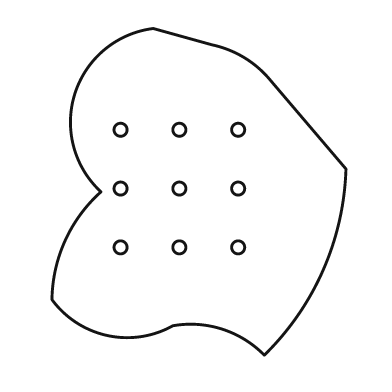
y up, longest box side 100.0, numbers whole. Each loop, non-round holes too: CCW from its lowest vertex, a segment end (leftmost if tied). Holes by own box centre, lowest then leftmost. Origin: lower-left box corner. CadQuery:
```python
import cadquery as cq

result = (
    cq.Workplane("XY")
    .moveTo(65.0, 0.0)
    .threePointArc((83.0, 26.0), (90.0, 57.0))
    .lineTo(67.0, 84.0)
    .threePointArc((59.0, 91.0), (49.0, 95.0))
    .lineTo(31.0, 100.0)
    .threePointArc((7.0, 80.0), (15.0, 50.0))
    .threePointArc((4.0, 35.0), (0.0, 17.0))
    .threePointArc((17.0, 6.0), (37.0, 9.0))
    .threePointArc((52.0, 8.0), (65.0, 0.0))
    .close()
    .moveTo(21.0, 33.0)
    .circle(2.0)
    .moveTo(39.0, 33.0)
    .circle(2.0)
    .moveTo(57.0, 33.0)
    .circle(2.0)
    .moveTo(21.0, 51.0)
    .circle(2.0)
    .moveTo(39.0, 51.0)
    .circle(2.0)
    .moveTo(57.0, 51.0)
    .circle(2.0)
    .moveTo(21.0, 69.0)
    .circle(2.0)
    .moveTo(39.0, 69.0)
    .circle(2.0)
    .moveTo(57.0, 69.0)
    .circle(2.0)
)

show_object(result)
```